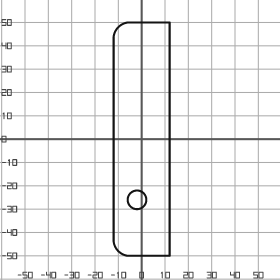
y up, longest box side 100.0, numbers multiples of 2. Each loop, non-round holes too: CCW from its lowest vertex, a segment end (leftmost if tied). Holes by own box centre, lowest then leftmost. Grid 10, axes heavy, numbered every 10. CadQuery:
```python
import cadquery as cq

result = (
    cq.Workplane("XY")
    .moveTo(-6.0, -50.0)
    .lineTo(12.0, -50.0)
    .lineTo(12.0, 50.0)
    .lineTo(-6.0, 50.0)
    .threePointArc((-10.0, 48.0), (-12.0, 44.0))
    .lineTo(-12.0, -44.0)
    .threePointArc((-10.0, -48.0), (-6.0, -50.0))
    .close()
    .moveTo(-2.0, -26.0)
    .circle(4.0)
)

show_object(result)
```